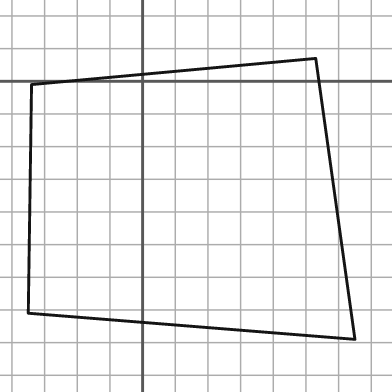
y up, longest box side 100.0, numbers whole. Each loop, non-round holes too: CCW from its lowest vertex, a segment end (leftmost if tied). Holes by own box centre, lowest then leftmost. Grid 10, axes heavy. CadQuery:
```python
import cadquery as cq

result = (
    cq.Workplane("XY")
    .moveTo(65.0, -79.0)
    .lineTo(53.0, 7.0)
    .lineTo(-34.0, -1.0)
    .lineTo(-35.0, -71.0)
    .close()
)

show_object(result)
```